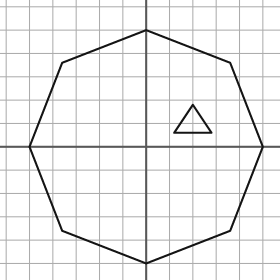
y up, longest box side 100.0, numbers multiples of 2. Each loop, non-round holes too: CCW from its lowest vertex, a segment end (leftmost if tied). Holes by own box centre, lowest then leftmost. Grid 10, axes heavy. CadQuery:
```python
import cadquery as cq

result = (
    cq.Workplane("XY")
    .moveTo(0.0, -50.0)
    .lineTo(36.0, -36.0)
    .lineTo(50.0, 0.0)
    .lineTo(36.0, 36.0)
    .lineTo(0.0, 50.0)
    .lineTo(-36.0, 36.0)
    .lineTo(-50.0, 0.0)
    .lineTo(-36.0, -36.0)
    .close()
    .moveTo(12.0, 6.0)
    .lineTo(28.0, 6.0)
    .lineTo(20.0, 18.0)
    .close()
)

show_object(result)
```